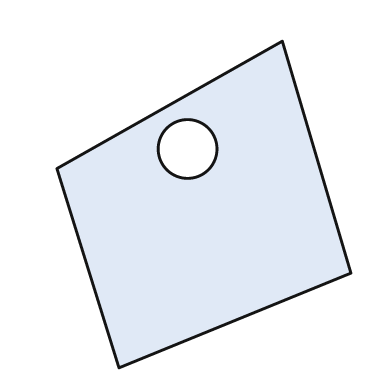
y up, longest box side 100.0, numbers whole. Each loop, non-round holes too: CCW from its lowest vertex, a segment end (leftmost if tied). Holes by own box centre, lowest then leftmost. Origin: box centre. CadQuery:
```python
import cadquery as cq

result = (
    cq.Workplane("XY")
    .moveTo(-26.0, -50.0)
    .lineTo(45.0, -21.0)
    .lineTo(24.0, 50.0)
    .lineTo(-45.0, 11.0)
    .close()
    .moveTo(-5.0, 17.0)
    .circle(9.0)
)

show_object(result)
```